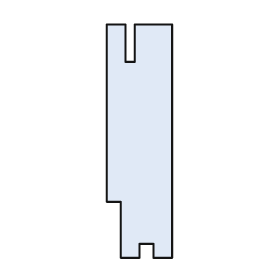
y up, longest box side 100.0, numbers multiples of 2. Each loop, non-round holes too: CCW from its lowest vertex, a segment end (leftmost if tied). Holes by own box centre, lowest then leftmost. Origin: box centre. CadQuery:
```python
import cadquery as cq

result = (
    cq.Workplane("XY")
    .moveTo(-8.0, -50.0)
    .lineTo(0.0, -50.0)
    .lineTo(0.0, -44.0)
    .lineTo(6.0, -44.0)
    .lineTo(6.0, -50.0)
    .lineTo(14.0, -50.0)
    .lineTo(14.0, 50.0)
    .lineTo(-2.0, 50.0)
    .lineTo(-2.0, 34.0)
    .lineTo(-6.0, 34.0)
    .lineTo(-6.0, 50.0)
    .lineTo(-14.0, 50.0)
    .lineTo(-14.0, -26.0)
    .lineTo(-8.0, -26.0)
    .close()
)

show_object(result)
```